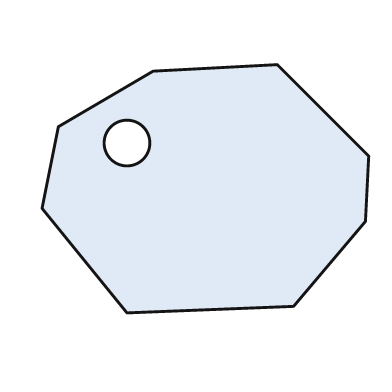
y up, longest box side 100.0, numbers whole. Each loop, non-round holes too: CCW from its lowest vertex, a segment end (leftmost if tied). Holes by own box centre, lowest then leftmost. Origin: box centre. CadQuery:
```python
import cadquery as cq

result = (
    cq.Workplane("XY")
    .moveTo(-24.0, -38.0)
    .lineTo(27.0, -36.0)
    .lineTo(49.0, -10.0)
    .lineTo(50.0, 10.0)
    .lineTo(22.0, 38.0)
    .lineTo(-16.0, 36.0)
    .lineTo(-45.0, 19.0)
    .lineTo(-50.0, -6.0)
    .close()
    .moveTo(-24.0, 14.0)
    .circle(7.0)
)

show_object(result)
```